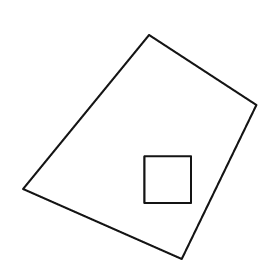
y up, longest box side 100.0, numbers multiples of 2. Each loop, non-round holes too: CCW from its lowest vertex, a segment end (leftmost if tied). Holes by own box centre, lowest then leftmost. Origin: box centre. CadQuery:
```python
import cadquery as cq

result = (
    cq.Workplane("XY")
    .moveTo(18.0, -48.0)
    .lineTo(50.0, 18.0)
    .lineTo(4.0, 48.0)
    .lineTo(-50.0, -18.0)
    .close()
    .moveTo(2.0, -24.0)
    .lineTo(22.0, -24.0)
    .lineTo(22.0, -4.0)
    .lineTo(2.0, -4.0)
    .close()
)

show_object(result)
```